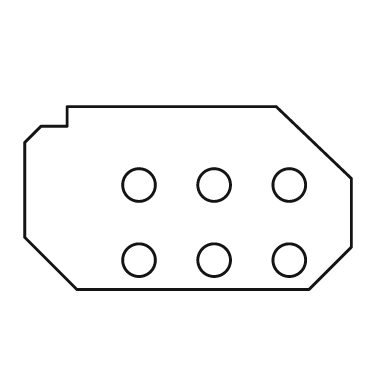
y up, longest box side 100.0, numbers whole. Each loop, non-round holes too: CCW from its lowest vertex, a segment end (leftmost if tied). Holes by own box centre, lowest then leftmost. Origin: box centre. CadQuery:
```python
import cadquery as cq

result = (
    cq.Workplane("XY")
    .moveTo(-34.0, -28.0)
    .lineTo(37.0, -28.0)
    .lineTo(50.0, -15.0)
    .lineTo(50.0, 6.0)
    .lineTo(27.0, 28.0)
    .lineTo(-37.0, 28.0)
    .lineTo(-37.0, 22.0)
    .lineTo(-45.0, 22.0)
    .lineTo(-50.0, 17.0)
    .lineTo(-50.0, -12.0)
    .close()
    .moveTo(-15.0, -19.0)
    .circle(5.0)
    .moveTo(8.0, -19.0)
    .circle(5.0)
    .moveTo(31.0, -19.0)
    .circle(5.0)
    .moveTo(-15.0, 4.0)
    .circle(5.0)
    .moveTo(8.0, 4.0)
    .circle(5.0)
    .moveTo(31.0, 4.0)
    .circle(5.0)
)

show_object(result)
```